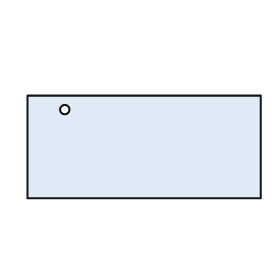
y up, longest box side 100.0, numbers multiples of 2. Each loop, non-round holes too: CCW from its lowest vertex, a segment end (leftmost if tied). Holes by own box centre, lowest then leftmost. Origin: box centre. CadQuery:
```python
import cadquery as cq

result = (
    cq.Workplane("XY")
    .moveTo(-50.0, -22.0)
    .lineTo(50.0, -22.0)
    .lineTo(50.0, 22.0)
    .lineTo(-50.0, 22.0)
    .close()
    .moveTo(-34.0, 16.0)
    .circle(2.0)
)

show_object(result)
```